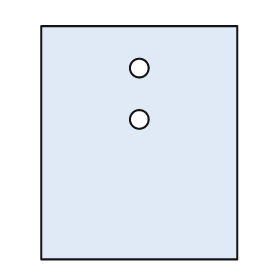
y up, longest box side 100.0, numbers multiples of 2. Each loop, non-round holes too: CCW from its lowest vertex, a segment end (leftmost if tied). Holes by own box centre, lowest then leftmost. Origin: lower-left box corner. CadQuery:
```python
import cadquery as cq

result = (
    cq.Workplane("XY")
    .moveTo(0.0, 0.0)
    .lineTo(84.0, 0.0)
    .lineTo(84.0, 100.0)
    .lineTo(0.0, 100.0)
    .close()
    .moveTo(42.0, 60.0)
    .circle(4.0)
    .moveTo(42.0, 82.0)
    .circle(4.0)
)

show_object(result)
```